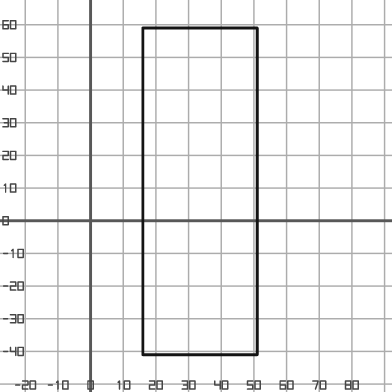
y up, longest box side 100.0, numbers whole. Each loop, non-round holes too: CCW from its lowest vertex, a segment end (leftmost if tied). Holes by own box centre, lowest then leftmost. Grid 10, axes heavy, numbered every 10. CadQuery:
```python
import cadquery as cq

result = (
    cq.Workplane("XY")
    .moveTo(16.0, -41.0)
    .lineTo(51.0, -41.0)
    .lineTo(51.0, 59.0)
    .lineTo(16.0, 59.0)
    .close()
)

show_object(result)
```